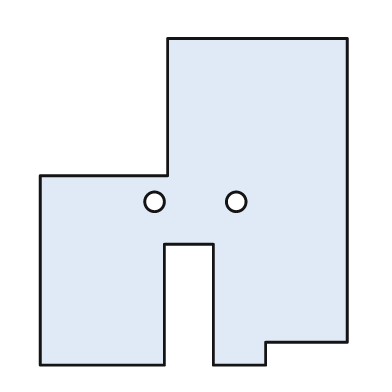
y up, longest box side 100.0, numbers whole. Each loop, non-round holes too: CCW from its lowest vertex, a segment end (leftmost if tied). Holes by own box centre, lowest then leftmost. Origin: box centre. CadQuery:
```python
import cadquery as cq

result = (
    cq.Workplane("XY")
    .moveTo(-47.0, -50.0)
    .lineTo(-9.0, -50.0)
    .lineTo(-9.0, -13.0)
    .lineTo(6.0, -13.0)
    .lineTo(6.0, -50.0)
    .lineTo(22.0, -50.0)
    .lineTo(22.0, -43.0)
    .lineTo(47.0, -43.0)
    .lineTo(47.0, 50.0)
    .lineTo(-8.0, 50.0)
    .lineTo(-8.0, 8.0)
    .lineTo(-47.0, 8.0)
    .close()
    .moveTo(-12.0, 0.0)
    .circle(3.0)
    .moveTo(13.0, 0.0)
    .circle(3.0)
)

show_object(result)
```